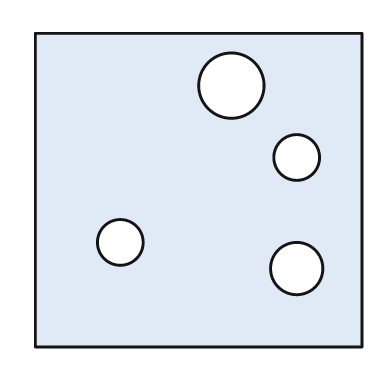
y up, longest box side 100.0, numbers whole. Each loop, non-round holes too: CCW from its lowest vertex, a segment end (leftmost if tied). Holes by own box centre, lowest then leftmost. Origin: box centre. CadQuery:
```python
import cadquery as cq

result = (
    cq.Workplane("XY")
    .moveTo(-50.0, -48.0)
    .lineTo(50.0, -48.0)
    .lineTo(50.0, 48.0)
    .lineTo(-50.0, 48.0)
    .close()
    .moveTo(30.0, -24.0)
    .circle(8.0)
    .moveTo(-24.0, -16.0)
    .circle(7.0)
    .moveTo(30.0, 10.0)
    .circle(7.0)
    .moveTo(10.0, 32.0)
    .circle(10.0)
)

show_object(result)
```